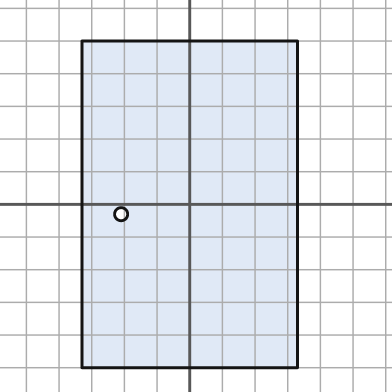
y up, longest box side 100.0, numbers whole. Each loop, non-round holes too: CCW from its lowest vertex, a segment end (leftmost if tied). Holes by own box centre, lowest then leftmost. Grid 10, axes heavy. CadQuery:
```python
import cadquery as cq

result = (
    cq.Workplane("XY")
    .moveTo(-33.0, -50.0)
    .lineTo(33.0, -50.0)
    .lineTo(33.0, 50.0)
    .lineTo(-33.0, 50.0)
    .close()
    .moveTo(-21.0, -3.0)
    .circle(2.0)
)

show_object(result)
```